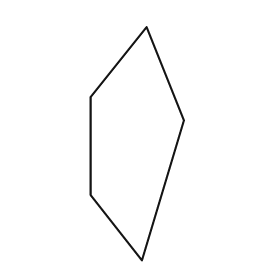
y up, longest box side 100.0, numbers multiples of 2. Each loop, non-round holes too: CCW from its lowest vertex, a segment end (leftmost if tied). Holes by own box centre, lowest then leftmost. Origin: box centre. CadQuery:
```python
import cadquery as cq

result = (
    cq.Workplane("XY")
    .moveTo(2.0, -50.0)
    .lineTo(20.0, 10.0)
    .lineTo(4.0, 50.0)
    .lineTo(-20.0, 20.0)
    .lineTo(-20.0, -22.0)
    .close()
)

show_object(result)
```